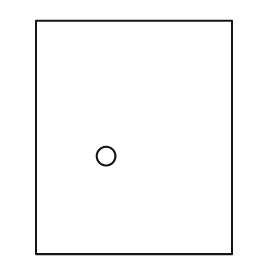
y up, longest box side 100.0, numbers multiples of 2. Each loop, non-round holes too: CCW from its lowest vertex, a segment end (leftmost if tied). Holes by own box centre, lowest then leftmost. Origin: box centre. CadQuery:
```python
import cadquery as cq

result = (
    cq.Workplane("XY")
    .moveTo(-42.0, -50.0)
    .lineTo(42.0, -50.0)
    .lineTo(42.0, 50.0)
    .lineTo(-42.0, 50.0)
    .close()
    .moveTo(-12.0, -8.0)
    .circle(4.0)
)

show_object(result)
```